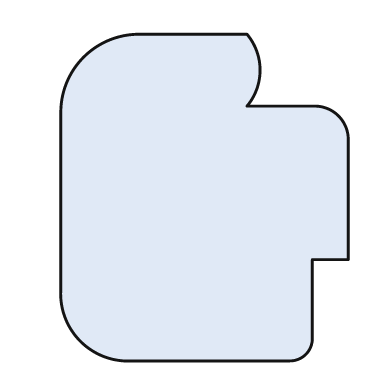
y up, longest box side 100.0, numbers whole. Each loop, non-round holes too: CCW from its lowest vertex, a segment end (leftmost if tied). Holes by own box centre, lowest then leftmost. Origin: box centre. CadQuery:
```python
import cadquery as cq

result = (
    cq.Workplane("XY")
    .moveTo(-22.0, -50.0)
    .lineTo(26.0, -50.0)
    .threePointArc((31.0, -48.0), (33.0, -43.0))
    .lineTo(33.0, -19.0)
    .lineTo(44.0, -19.0)
    .lineTo(44.0, 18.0)
    .threePointArc((41.0, 25.0), (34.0, 28.0))
    .lineTo(13.0, 28.0)
    .threePointArc((17.0, 39.0), (13.0, 50.0))
    .lineTo(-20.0, 50.0)
    .threePointArc((-37.0, 43.0), (-44.0, 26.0))
    .lineTo(-44.0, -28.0)
    .threePointArc((-38.0, -44.0), (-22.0, -50.0))
    .close()
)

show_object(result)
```